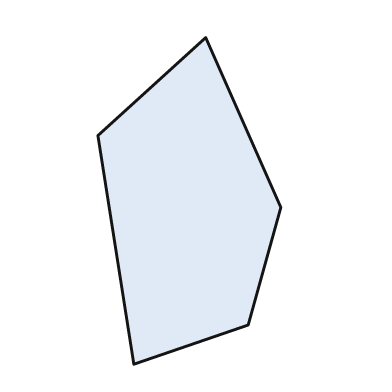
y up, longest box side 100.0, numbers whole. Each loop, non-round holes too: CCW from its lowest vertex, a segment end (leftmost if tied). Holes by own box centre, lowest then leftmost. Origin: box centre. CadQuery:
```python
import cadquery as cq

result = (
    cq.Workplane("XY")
    .moveTo(-17.0, -50.0)
    .lineTo(18.0, -38.0)
    .lineTo(28.0, -2.0)
    .lineTo(5.0, 50.0)
    .lineTo(-28.0, 20.0)
    .close()
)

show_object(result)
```